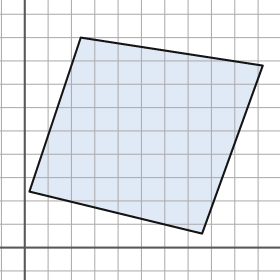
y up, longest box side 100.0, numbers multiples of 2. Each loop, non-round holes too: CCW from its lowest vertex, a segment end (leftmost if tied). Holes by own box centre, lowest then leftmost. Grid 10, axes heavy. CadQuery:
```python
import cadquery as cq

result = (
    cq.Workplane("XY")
    .moveTo(76.0, 6.0)
    .lineTo(102.0, 78.0)
    .lineTo(24.0, 90.0)
    .lineTo(2.0, 24.0)
    .close()
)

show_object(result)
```